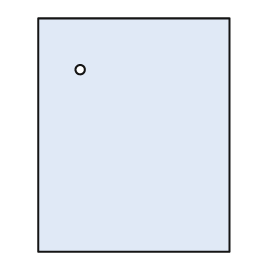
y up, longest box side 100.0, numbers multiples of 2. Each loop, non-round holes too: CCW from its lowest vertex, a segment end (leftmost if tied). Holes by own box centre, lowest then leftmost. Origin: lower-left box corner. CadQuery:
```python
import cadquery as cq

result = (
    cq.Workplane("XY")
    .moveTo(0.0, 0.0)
    .lineTo(82.0, 0.0)
    .lineTo(82.0, 100.0)
    .lineTo(0.0, 100.0)
    .close()
    .moveTo(18.0, 78.0)
    .circle(2.0)
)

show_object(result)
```